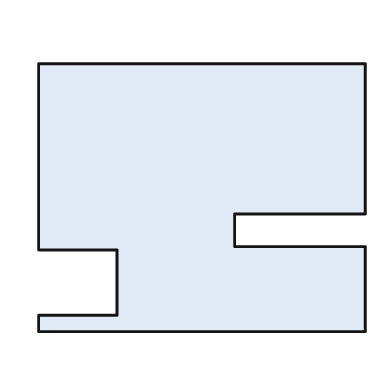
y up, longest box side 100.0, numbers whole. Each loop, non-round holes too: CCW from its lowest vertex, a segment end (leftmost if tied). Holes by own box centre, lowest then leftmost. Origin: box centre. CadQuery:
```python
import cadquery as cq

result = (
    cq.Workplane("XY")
    .moveTo(-50.0, -41.0)
    .lineTo(50.0, -41.0)
    .lineTo(50.0, -15.0)
    .lineTo(10.0, -15.0)
    .lineTo(10.0, -5.0)
    .lineTo(50.0, -5.0)
    .lineTo(50.0, 41.0)
    .lineTo(-50.0, 41.0)
    .lineTo(-50.0, -16.0)
    .lineTo(-26.0, -16.0)
    .lineTo(-26.0, -36.0)
    .lineTo(-50.0, -36.0)
    .close()
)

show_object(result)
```